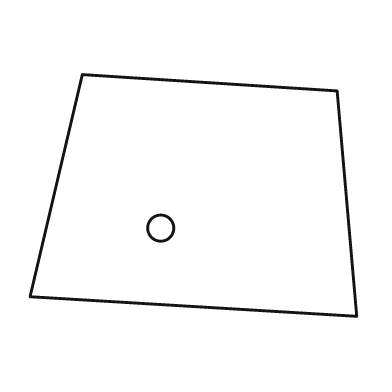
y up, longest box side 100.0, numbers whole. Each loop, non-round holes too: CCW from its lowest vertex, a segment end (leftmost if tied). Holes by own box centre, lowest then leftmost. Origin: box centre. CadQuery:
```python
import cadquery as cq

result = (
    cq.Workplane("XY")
    .moveTo(50.0, -37.0)
    .lineTo(44.0, 32.0)
    .lineTo(-34.0, 37.0)
    .lineTo(-50.0, -31.0)
    .close()
    .moveTo(-10.0, -10.0)
    .circle(4.0)
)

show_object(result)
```